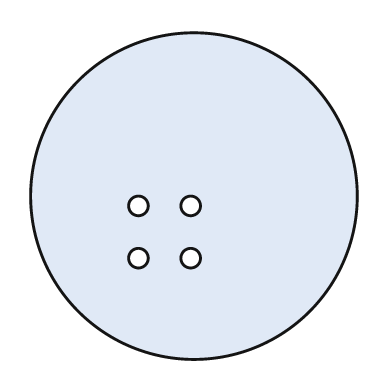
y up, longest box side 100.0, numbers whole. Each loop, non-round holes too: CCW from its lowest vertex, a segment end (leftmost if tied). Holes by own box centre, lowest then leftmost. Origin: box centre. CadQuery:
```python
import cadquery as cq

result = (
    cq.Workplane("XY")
    .moveTo(0.0, 0.0)
    .circle(50.0)
    .moveTo(-17.0, -19.0)
    .circle(3.0)
    .moveTo(-1.0, -19.0)
    .circle(3.0)
    .moveTo(-17.0, -3.0)
    .circle(3.0)
    .moveTo(-1.0, -3.0)
    .circle(3.0)
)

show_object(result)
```